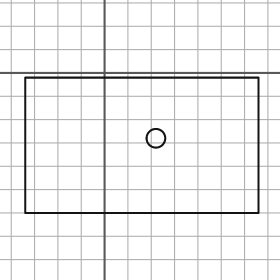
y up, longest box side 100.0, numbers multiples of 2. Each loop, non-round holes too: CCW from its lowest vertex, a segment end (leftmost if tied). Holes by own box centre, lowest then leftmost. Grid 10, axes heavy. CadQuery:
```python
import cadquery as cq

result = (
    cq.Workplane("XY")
    .moveTo(-34.0, -60.0)
    .lineTo(66.0, -60.0)
    .lineTo(66.0, -2.0)
    .lineTo(-34.0, -2.0)
    .close()
    .moveTo(22.0, -28.0)
    .circle(4.0)
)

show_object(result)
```